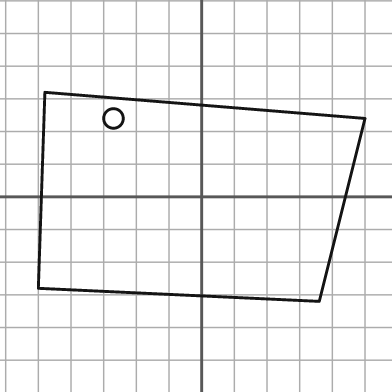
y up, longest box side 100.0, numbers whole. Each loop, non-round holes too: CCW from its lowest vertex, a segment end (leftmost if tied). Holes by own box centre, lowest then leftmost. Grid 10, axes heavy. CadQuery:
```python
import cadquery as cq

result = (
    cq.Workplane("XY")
    .moveTo(36.0, -32.0)
    .lineTo(50.0, 24.0)
    .lineTo(-48.0, 32.0)
    .lineTo(-50.0, -28.0)
    .close()
    .moveTo(-27.0, 24.0)
    .circle(3.0)
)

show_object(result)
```